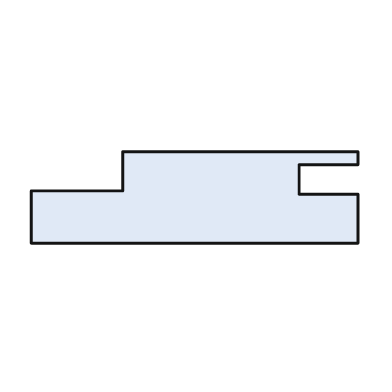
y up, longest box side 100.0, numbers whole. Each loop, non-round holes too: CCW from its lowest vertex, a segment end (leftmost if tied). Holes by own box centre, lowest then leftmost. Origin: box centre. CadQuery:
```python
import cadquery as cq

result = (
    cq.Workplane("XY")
    .moveTo(-50.0, -14.0)
    .lineTo(50.0, -14.0)
    .lineTo(50.0, 1.0)
    .lineTo(32.0, 1.0)
    .lineTo(32.0, 10.0)
    .lineTo(50.0, 10.0)
    .lineTo(50.0, 14.0)
    .lineTo(-22.0, 14.0)
    .lineTo(-22.0, 2.0)
    .lineTo(-50.0, 2.0)
    .close()
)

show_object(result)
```